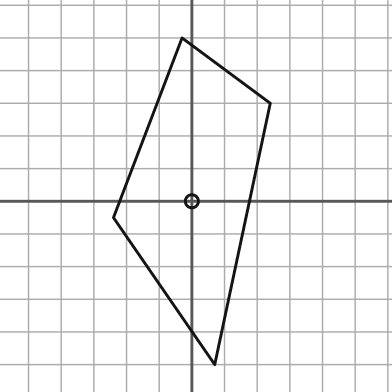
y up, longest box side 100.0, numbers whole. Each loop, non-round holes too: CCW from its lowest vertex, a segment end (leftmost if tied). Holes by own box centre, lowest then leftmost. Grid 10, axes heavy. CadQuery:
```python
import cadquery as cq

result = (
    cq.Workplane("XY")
    .moveTo(7.0, -50.0)
    .lineTo(24.0, 30.0)
    .lineTo(-3.0, 50.0)
    .lineTo(-24.0, -5.0)
    .close()
    .moveTo(0.0, 0.0)
    .circle(2.0)
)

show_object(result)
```